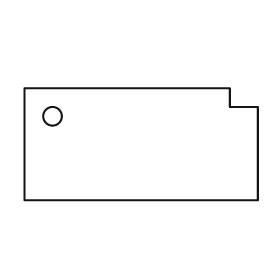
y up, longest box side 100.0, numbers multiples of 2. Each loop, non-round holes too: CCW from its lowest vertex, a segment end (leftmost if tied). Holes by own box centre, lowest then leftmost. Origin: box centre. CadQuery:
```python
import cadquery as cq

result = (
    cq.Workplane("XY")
    .moveTo(-50.0, -24.0)
    .lineTo(50.0, -24.0)
    .lineTo(50.0, 16.0)
    .lineTo(38.0, 16.0)
    .lineTo(38.0, 24.0)
    .lineTo(-50.0, 24.0)
    .close()
    .moveTo(-38.0, 12.0)
    .circle(4.0)
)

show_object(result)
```